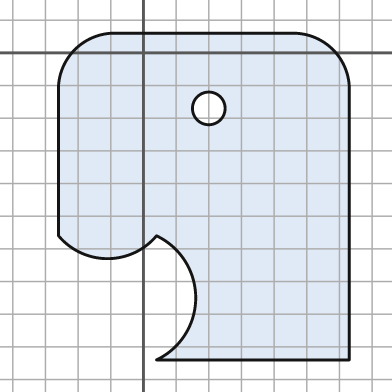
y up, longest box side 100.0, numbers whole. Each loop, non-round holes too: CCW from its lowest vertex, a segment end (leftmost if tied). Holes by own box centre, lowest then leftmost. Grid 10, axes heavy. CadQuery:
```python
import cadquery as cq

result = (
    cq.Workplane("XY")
    .moveTo(4.0, -94.0)
    .lineTo(63.0, -94.0)
    .lineTo(63.0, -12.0)
    .threePointArc((58.0, 1.0), (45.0, 6.0))
    .lineTo(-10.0, 6.0)
    .threePointArc((-21.0, 1.0), (-26.0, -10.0))
    .lineTo(-26.0, -56.0)
    .threePointArc((-11.0, -63.0), (4.0, -56.0))
    .threePointArc((16.0, -75.0), (4.0, -94.0))
    .close()
    .moveTo(20.0, -17.0)
    .circle(5.0)
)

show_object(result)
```